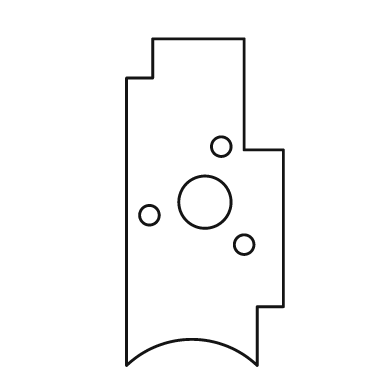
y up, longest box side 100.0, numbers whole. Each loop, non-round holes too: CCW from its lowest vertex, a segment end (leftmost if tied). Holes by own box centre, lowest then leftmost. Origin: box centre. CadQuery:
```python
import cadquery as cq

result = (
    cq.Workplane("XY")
    .moveTo(-24.0, -50.0)
    .threePointArc((-4.0, -42.0), (16.0, -50.0))
    .lineTo(16.0, -32.0)
    .lineTo(24.0, -32.0)
    .lineTo(24.0, 16.0)
    .lineTo(12.0, 16.0)
    .lineTo(12.0, 50.0)
    .lineTo(-16.0, 50.0)
    .lineTo(-16.0, 38.0)
    .lineTo(-24.0, 38.0)
    .close()
    .moveTo(12.0, -13.0)
    .circle(3.0)
    .moveTo(-17.0, -4.0)
    .circle(3.0)
    .moveTo(0.0, 0.0)
    .circle(8.0)
    .moveTo(5.0, 17.0)
    .circle(3.0)
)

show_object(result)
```